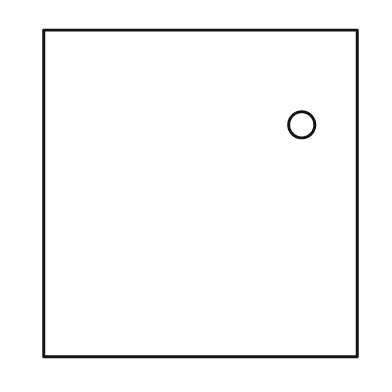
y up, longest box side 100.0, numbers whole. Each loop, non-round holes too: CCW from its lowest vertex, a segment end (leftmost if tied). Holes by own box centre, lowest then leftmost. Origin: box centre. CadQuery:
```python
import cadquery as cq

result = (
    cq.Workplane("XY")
    .moveTo(-48.0, -50.0)
    .lineTo(48.0, -50.0)
    .lineTo(48.0, 50.0)
    .lineTo(-48.0, 50.0)
    .close()
    .moveTo(31.0, 21.0)
    .circle(4.0)
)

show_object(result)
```